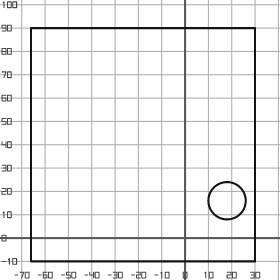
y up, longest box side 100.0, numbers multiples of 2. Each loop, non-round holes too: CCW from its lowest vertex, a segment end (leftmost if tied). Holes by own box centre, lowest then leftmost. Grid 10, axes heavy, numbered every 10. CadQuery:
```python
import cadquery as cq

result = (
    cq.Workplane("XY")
    .moveTo(-66.0, -10.0)
    .lineTo(30.0, -10.0)
    .lineTo(30.0, 90.0)
    .lineTo(-66.0, 90.0)
    .close()
    .moveTo(18.0, 16.0)
    .circle(8.0)
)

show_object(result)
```